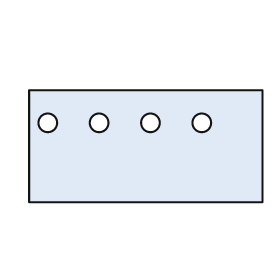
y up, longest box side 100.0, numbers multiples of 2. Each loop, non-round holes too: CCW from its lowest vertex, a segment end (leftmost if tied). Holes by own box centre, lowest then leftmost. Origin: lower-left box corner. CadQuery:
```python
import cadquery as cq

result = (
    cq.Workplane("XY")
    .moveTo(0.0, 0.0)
    .lineTo(100.0, 0.0)
    .lineTo(100.0, 48.0)
    .lineTo(0.0, 48.0)
    .close()
    .moveTo(8.0, 34.0)
    .circle(4.0)
    .moveTo(30.0, 34.0)
    .circle(4.0)
    .moveTo(52.0, 34.0)
    .circle(4.0)
    .moveTo(74.0, 34.0)
    .circle(4.0)
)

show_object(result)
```